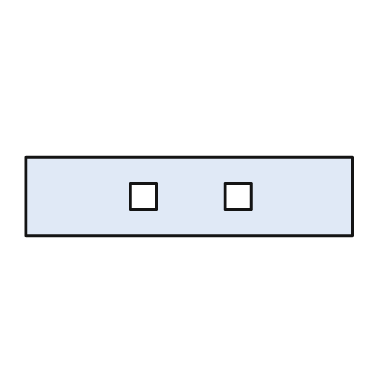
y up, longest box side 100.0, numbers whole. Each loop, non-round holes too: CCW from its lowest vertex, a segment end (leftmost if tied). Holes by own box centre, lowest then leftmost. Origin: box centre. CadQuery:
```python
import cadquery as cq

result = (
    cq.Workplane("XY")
    .moveTo(-50.0, -12.0)
    .lineTo(50.0, -12.0)
    .lineTo(50.0, 12.0)
    .lineTo(-50.0, 12.0)
    .close()
    .moveTo(-18.0, -4.0)
    .lineTo(-10.0, -4.0)
    .lineTo(-10.0, 4.0)
    .lineTo(-18.0, 4.0)
    .close()
    .moveTo(11.0, -4.0)
    .lineTo(19.0, -4.0)
    .lineTo(19.0, 4.0)
    .lineTo(11.0, 4.0)
    .close()
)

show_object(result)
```